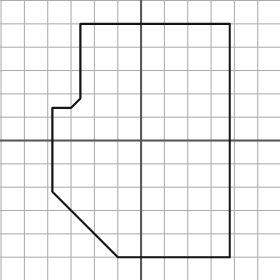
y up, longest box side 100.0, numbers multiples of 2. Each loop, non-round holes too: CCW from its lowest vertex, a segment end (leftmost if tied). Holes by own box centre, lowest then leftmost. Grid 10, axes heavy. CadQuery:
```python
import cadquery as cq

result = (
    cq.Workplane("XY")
    .moveTo(-10.0, -50.0)
    .lineTo(38.0, -50.0)
    .lineTo(38.0, 50.0)
    .lineTo(-26.0, 50.0)
    .lineTo(-26.0, 18.0)
    .lineTo(-30.0, 14.0)
    .lineTo(-38.0, 14.0)
    .lineTo(-38.0, -22.0)
    .close()
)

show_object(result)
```